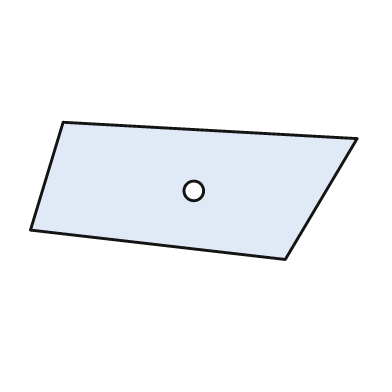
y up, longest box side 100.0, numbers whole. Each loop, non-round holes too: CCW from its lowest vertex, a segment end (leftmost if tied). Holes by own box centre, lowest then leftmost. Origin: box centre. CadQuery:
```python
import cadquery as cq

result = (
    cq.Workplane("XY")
    .moveTo(28.0, -21.0)
    .lineTo(50.0, 16.0)
    .lineTo(-40.0, 21.0)
    .lineTo(-50.0, -12.0)
    .close()
    .moveTo(0.0, 0.0)
    .circle(3.0)
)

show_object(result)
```